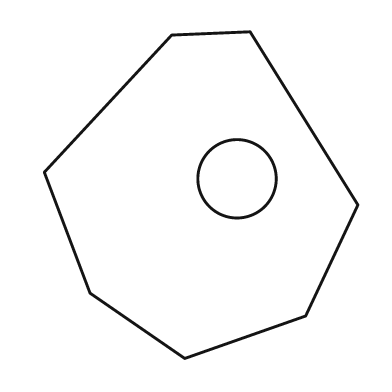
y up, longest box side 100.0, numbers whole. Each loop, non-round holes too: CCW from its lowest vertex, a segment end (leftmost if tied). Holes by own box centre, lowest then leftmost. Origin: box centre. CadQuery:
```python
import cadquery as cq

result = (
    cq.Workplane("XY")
    .moveTo(-5.0, -50.0)
    .lineTo(32.0, -37.0)
    .lineTo(48.0, -3.0)
    .lineTo(15.0, 50.0)
    .lineTo(-9.0, 49.0)
    .lineTo(-48.0, 7.0)
    .lineTo(-34.0, -30.0)
    .close()
    .moveTo(11.0, 5.0)
    .circle(12.0)
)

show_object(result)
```